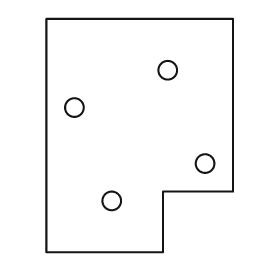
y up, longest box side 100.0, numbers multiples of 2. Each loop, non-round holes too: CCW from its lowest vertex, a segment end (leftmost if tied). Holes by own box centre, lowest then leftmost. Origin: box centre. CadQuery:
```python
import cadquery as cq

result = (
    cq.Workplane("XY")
    .moveTo(-40.0, -50.0)
    .lineTo(10.0, -50.0)
    .lineTo(10.0, -24.0)
    .lineTo(40.0, -24.0)
    .lineTo(40.0, 50.0)
    .lineTo(-40.0, 50.0)
    .close()
    .moveTo(-12.0, -28.0)
    .circle(4.0)
    .moveTo(28.0, -12.0)
    .circle(4.0)
    .moveTo(-28.0, 12.0)
    .circle(4.0)
    .moveTo(12.0, 28.0)
    .circle(4.0)
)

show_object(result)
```